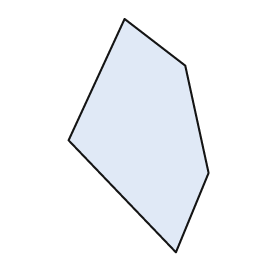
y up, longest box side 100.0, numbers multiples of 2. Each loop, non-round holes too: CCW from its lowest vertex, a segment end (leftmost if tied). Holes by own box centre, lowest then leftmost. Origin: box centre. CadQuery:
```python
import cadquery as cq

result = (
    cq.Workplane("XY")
    .moveTo(16.0, -50.0)
    .lineTo(30.0, -16.0)
    .lineTo(20.0, 30.0)
    .lineTo(-6.0, 50.0)
    .lineTo(-30.0, -2.0)
    .close()
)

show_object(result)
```